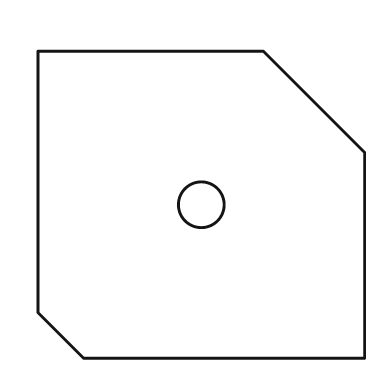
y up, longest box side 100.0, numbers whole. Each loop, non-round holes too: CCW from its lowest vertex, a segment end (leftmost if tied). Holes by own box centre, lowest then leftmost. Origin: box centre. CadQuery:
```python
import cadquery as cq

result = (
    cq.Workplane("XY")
    .moveTo(-36.0, -47.0)
    .lineTo(50.0, -47.0)
    .lineTo(50.0, 16.0)
    .lineTo(19.0, 47.0)
    .lineTo(-50.0, 47.0)
    .lineTo(-50.0, -33.0)
    .close()
    .moveTo(0.0, 0.0)
    .circle(7.0)
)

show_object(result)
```